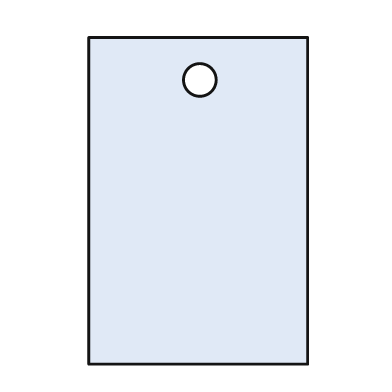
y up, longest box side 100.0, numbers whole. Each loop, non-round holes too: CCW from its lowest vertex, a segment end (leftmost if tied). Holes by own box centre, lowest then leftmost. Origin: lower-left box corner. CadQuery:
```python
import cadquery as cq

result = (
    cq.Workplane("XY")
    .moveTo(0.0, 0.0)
    .lineTo(67.0, 0.0)
    .lineTo(67.0, 100.0)
    .lineTo(0.0, 100.0)
    .close()
    .moveTo(34.0, 87.0)
    .circle(5.0)
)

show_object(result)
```